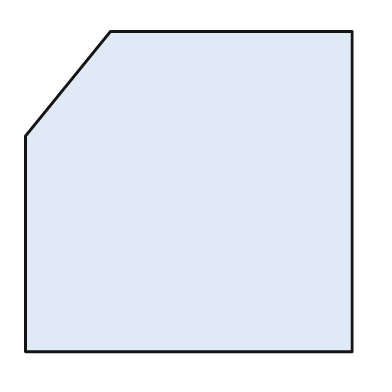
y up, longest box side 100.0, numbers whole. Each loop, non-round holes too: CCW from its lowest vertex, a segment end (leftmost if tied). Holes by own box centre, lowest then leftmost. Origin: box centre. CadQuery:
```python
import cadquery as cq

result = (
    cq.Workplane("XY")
    .moveTo(-50.0, -49.0)
    .lineTo(50.0, -49.0)
    .lineTo(50.0, 49.0)
    .lineTo(-24.0, 49.0)
    .lineTo(-50.0, 17.0)
    .close()
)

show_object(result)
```